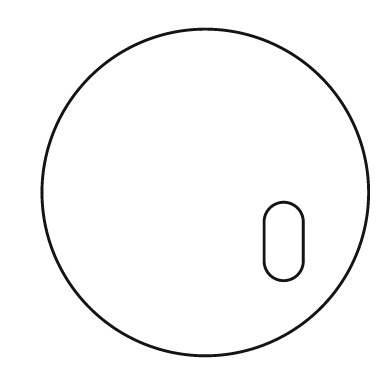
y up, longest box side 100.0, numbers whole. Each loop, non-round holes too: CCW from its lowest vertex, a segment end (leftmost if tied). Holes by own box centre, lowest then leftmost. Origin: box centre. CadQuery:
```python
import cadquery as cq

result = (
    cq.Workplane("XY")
    .moveTo(0.0, 0.0)
    .circle(50.0)
    .moveTo(18.0, -21.0)
    .threePointArc((24.0, -27.0), (30.0, -21.0))
    .lineTo(30.0, -9.0)
    .threePointArc((24.0, -3.0), (18.0, -9.0))
    .close()
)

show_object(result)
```